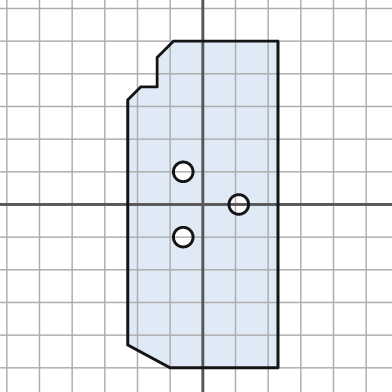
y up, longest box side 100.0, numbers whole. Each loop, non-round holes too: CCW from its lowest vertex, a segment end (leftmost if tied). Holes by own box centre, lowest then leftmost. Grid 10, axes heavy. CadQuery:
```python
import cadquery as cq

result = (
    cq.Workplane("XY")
    .moveTo(-10.0, -50.0)
    .lineTo(23.0, -50.0)
    .lineTo(23.0, 50.0)
    .lineTo(-9.0, 50.0)
    .lineTo(-14.0, 45.0)
    .lineTo(-14.0, 36.0)
    .lineTo(-19.0, 36.0)
    .lineTo(-23.0, 32.0)
    .lineTo(-23.0, -43.0)
    .close()
    .moveTo(-6.0, -10.0)
    .circle(3.0)
    .moveTo(11.0, 0.0)
    .circle(3.0)
    .moveTo(-6.0, 10.0)
    .circle(3.0)
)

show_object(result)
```